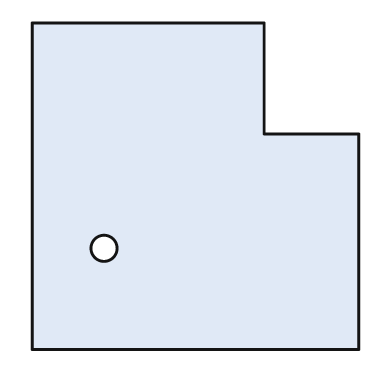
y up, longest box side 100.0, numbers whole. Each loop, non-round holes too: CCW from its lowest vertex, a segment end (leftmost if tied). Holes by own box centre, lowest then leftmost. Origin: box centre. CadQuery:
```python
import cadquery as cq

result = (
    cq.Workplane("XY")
    .moveTo(-50.0, -50.0)
    .lineTo(50.0, -50.0)
    .lineTo(50.0, 16.0)
    .lineTo(21.0, 16.0)
    .lineTo(21.0, 50.0)
    .lineTo(-50.0, 50.0)
    .close()
    .moveTo(-28.0, -19.0)
    .circle(4.0)
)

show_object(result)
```